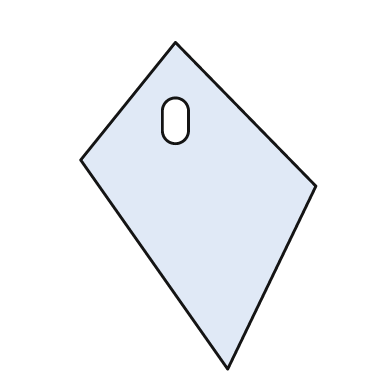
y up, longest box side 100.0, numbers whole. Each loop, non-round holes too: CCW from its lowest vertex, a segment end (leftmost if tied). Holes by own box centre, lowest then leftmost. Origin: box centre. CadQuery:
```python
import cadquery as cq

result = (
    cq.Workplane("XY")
    .moveTo(9.0, -50.0)
    .lineTo(36.0, 6.0)
    .lineTo(-7.0, 50.0)
    .lineTo(-36.0, 14.0)
    .close()
    .moveTo(-11.0, 23.0)
    .threePointArc((-7.0, 19.0), (-3.0, 23.0))
    .lineTo(-3.0, 29.0)
    .threePointArc((-7.0, 33.0), (-11.0, 29.0))
    .close()
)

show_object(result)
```